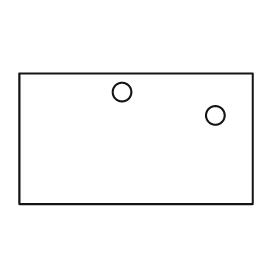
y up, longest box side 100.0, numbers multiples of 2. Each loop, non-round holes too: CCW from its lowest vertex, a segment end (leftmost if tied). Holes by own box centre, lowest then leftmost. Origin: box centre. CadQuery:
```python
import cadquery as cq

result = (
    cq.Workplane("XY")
    .moveTo(-50.0, -28.0)
    .lineTo(50.0, -28.0)
    .lineTo(50.0, 28.0)
    .lineTo(-50.0, 28.0)
    .close()
    .moveTo(34.0, 10.0)
    .circle(4.0)
    .moveTo(-6.0, 20.0)
    .circle(4.0)
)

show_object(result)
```